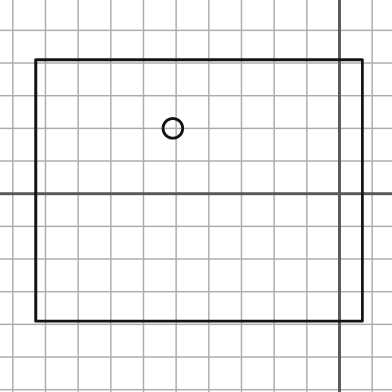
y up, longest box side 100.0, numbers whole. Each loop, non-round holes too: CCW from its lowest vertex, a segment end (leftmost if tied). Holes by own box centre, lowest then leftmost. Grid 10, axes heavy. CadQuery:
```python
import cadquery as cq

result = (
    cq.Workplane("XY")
    .moveTo(-93.0, -39.0)
    .lineTo(7.0, -39.0)
    .lineTo(7.0, 41.0)
    .lineTo(-93.0, 41.0)
    .close()
    .moveTo(-51.0, 20.0)
    .circle(3.0)
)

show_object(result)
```